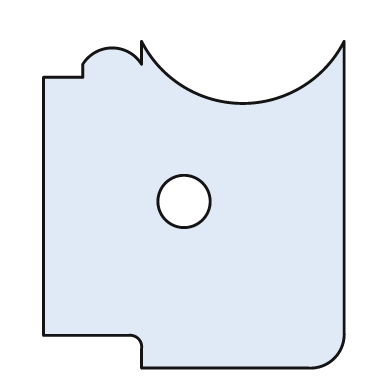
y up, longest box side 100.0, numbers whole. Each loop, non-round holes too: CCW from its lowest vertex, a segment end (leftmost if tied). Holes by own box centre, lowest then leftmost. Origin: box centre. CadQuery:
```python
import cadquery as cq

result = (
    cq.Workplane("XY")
    .moveTo(-16.0, -50.0)
    .lineTo(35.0, -50.0)
    .threePointArc((43.0, -47.0), (46.0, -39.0))
    .lineTo(46.0, 50.0)
    .threePointArc((15.0, 31.0), (-16.0, 50.0))
    .lineTo(-16.0, 43.0)
    .threePointArc((-25.0, 48.0), (-34.0, 43.0))
    .lineTo(-34.0, 39.0)
    .lineTo(-46.0, 39.0)
    .lineTo(-46.0, -40.0)
    .lineTo(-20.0, -40.0)
    .threePointArc((-17.0, -41.0), (-16.0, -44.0))
    .close()
    .moveTo(-3.0, 1.0)
    .circle(8.0)
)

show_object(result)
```